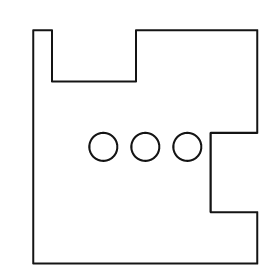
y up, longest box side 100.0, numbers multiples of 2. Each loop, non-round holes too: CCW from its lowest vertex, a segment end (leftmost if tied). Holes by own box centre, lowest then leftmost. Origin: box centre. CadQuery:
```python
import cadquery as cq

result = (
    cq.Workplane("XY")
    .moveTo(-48.0, -50.0)
    .lineTo(48.0, -50.0)
    .lineTo(48.0, -28.0)
    .lineTo(28.0, -28.0)
    .lineTo(28.0, 6.0)
    .lineTo(48.0, 6.0)
    .lineTo(48.0, 50.0)
    .lineTo(-4.0, 50.0)
    .lineTo(-4.0, 28.0)
    .lineTo(-40.0, 28.0)
    .lineTo(-40.0, 50.0)
    .lineTo(-48.0, 50.0)
    .close()
    .moveTo(-18.0, 0.0)
    .circle(6.0)
    .moveTo(0.0, 0.0)
    .circle(6.0)
    .moveTo(18.0, 0.0)
    .circle(6.0)
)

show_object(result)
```